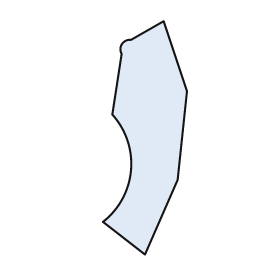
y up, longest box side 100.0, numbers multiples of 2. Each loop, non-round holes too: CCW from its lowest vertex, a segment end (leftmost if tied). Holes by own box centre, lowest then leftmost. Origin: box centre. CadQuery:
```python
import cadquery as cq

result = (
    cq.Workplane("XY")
    .moveTo(0.0, -50.0)
    .lineTo(14.0, -18.0)
    .lineTo(18.0, 20.0)
    .lineTo(8.0, 50.0)
    .lineTo(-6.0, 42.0)
    .threePointArc((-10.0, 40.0), (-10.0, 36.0))
    .lineTo(-14.0, 10.0)
    .threePointArc((-6.0, -14.0), (-18.0, -36.0))
    .close()
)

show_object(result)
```